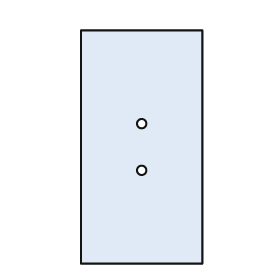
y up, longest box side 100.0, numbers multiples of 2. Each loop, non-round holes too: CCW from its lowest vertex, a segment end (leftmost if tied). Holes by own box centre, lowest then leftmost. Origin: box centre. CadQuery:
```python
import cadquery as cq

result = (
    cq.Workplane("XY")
    .moveTo(-26.0, -50.0)
    .lineTo(26.0, -50.0)
    .lineTo(26.0, 50.0)
    .lineTo(-26.0, 50.0)
    .close()
    .moveTo(0.0, -10.0)
    .circle(2.0)
    .moveTo(0.0, 10.0)
    .circle(2.0)
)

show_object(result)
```